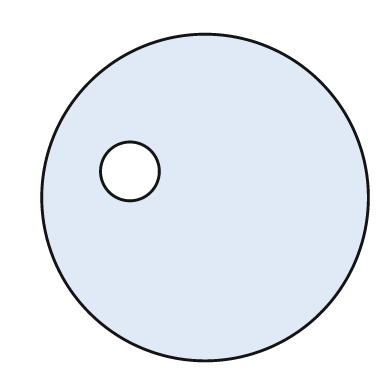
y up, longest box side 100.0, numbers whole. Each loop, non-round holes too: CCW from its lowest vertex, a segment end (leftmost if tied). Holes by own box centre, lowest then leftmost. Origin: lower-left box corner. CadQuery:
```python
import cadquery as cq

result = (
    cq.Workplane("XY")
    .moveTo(50.0, 50.0)
    .circle(50.0)
    .moveTo(27.0, 58.0)
    .circle(9.0)
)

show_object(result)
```